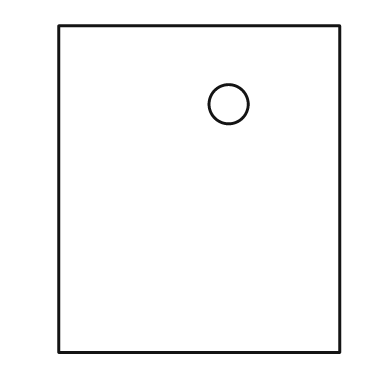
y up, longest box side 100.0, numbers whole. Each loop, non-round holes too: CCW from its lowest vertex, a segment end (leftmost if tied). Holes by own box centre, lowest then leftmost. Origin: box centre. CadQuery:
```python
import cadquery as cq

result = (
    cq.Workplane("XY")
    .moveTo(-43.0, -50.0)
    .lineTo(43.0, -50.0)
    .lineTo(43.0, 50.0)
    .lineTo(-43.0, 50.0)
    .close()
    .moveTo(9.0, 26.0)
    .circle(6.0)
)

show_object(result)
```